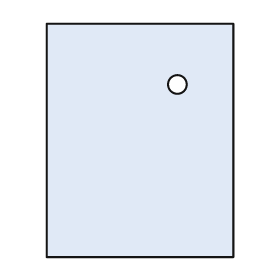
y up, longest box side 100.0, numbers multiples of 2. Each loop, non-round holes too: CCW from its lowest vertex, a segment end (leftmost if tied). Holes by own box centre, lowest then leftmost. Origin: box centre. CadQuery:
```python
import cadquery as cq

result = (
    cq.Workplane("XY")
    .moveTo(-40.0, -50.0)
    .lineTo(40.0, -50.0)
    .lineTo(40.0, 50.0)
    .lineTo(-40.0, 50.0)
    .close()
    .moveTo(16.0, 24.0)
    .circle(4.0)
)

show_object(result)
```